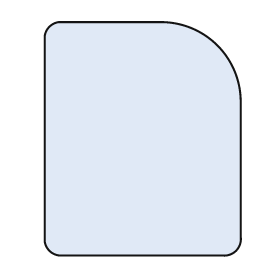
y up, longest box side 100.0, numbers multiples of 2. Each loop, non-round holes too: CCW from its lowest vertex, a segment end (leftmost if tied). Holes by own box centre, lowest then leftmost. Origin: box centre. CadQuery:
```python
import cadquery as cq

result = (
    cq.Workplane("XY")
    .moveTo(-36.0, -50.0)
    .lineTo(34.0, -50.0)
    .threePointArc((40.0, -48.0), (42.0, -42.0))
    .lineTo(42.0, 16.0)
    .threePointArc((32.0, 40.0), (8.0, 50.0))
    .lineTo(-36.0, 50.0)
    .threePointArc((-40.0, 48.0), (-42.0, 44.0))
    .lineTo(-42.0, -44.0)
    .threePointArc((-40.0, -48.0), (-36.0, -50.0))
    .close()
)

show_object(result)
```